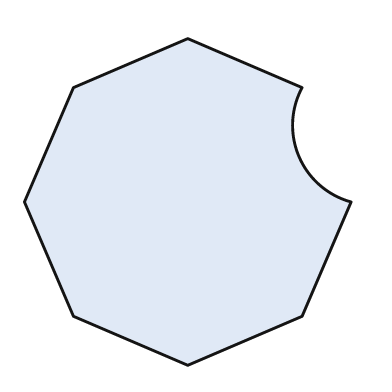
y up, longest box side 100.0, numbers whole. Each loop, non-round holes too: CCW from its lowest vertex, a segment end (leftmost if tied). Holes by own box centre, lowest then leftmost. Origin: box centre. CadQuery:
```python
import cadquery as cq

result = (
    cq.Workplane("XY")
    .moveTo(0.0, -50.0)
    .lineTo(35.0, -35.0)
    .lineTo(50.0, 0.0)
    .threePointArc((34.0, 14.0), (35.0, 35.0))
    .lineTo(0.0, 50.0)
    .lineTo(-35.0, 35.0)
    .lineTo(-50.0, 0.0)
    .lineTo(-35.0, -35.0)
    .close()
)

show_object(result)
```